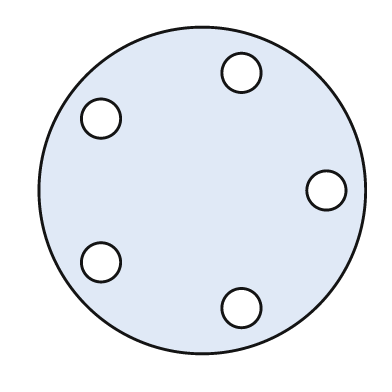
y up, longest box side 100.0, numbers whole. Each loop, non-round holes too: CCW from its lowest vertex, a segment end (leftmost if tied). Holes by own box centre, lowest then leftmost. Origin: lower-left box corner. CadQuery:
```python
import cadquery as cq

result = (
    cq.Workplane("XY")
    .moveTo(50.0, 50.0)
    .circle(50.0)
    .moveTo(62.0, 14.0)
    .circle(6.0)
    .moveTo(19.0, 28.0)
    .circle(6.0)
    .moveTo(88.0, 50.0)
    .circle(6.0)
    .moveTo(19.0, 72.0)
    .circle(6.0)
    .moveTo(62.0, 86.0)
    .circle(6.0)
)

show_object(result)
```